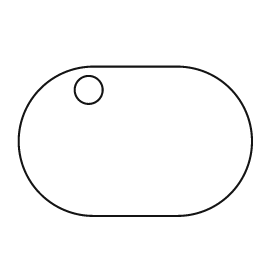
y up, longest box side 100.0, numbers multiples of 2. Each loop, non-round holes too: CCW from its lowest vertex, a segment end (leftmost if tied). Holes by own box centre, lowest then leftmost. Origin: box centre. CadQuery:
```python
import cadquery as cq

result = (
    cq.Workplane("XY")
    .moveTo(-18.0, -32.0)
    .lineTo(18.0, -32.0)
    .threePointArc((50.0, 0.0), (18.0, 32.0))
    .lineTo(-18.0, 32.0)
    .threePointArc((-50.0, 0.0), (-18.0, -32.0))
    .close()
    .moveTo(-20.0, 22.0)
    .circle(6.0)
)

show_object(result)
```